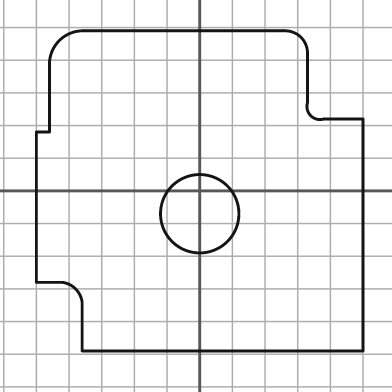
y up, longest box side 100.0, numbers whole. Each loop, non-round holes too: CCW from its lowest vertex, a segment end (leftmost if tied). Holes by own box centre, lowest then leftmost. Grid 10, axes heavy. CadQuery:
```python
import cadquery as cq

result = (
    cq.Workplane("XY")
    .moveTo(-36.0, -49.0)
    .lineTo(50.0, -49.0)
    .lineTo(50.0, 22.0)
    .lineTo(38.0, 22.0)
    .threePointArc((34.0, 23.0), (33.0, 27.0))
    .lineTo(33.0, 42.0)
    .threePointArc((31.0, 47.0), (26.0, 49.0))
    .lineTo(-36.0, 49.0)
    .threePointArc((-43.0, 46.0), (-46.0, 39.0))
    .lineTo(-46.0, 18.0)
    .lineTo(-50.0, 18.0)
    .lineTo(-50.0, -28.0)
    .lineTo(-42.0, -28.0)
    .threePointArc((-38.0, -30.0), (-36.0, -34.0))
    .close()
    .moveTo(0.0, -7.0)
    .circle(12.0)
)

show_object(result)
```